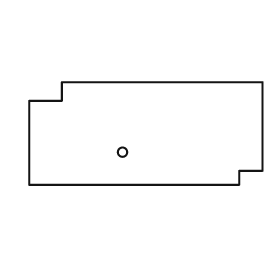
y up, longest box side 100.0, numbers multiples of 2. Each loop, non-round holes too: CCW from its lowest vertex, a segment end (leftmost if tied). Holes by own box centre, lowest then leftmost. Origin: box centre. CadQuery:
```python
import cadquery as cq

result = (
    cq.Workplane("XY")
    .moveTo(-50.0, -22.0)
    .lineTo(40.0, -22.0)
    .lineTo(40.0, -16.0)
    .lineTo(50.0, -16.0)
    .lineTo(50.0, 22.0)
    .lineTo(-36.0, 22.0)
    .lineTo(-36.0, 14.0)
    .lineTo(-50.0, 14.0)
    .close()
    .moveTo(-10.0, -8.0)
    .circle(2.0)
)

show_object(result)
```